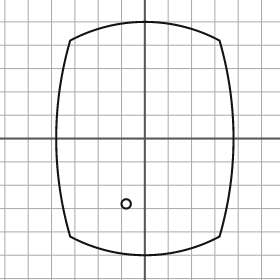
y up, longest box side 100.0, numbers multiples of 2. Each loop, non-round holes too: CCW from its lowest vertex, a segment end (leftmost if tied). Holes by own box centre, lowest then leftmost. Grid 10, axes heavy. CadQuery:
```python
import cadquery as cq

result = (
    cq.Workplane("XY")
    .moveTo(-32.0, -42.0)
    .threePointArc((0.0, -50.0), (32.0, -42.0))
    .threePointArc((38.0, 0.0), (32.0, 42.0))
    .threePointArc((0.0, 50.0), (-32.0, 42.0))
    .threePointArc((-38.0, 0.0), (-32.0, -42.0))
    .close()
    .moveTo(-8.0, -28.0)
    .circle(2.0)
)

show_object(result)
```